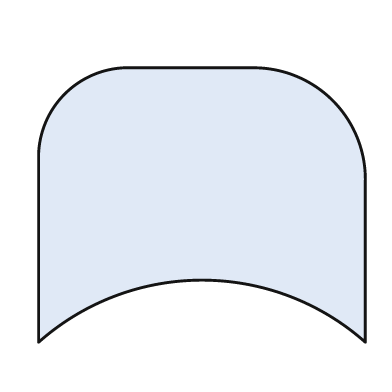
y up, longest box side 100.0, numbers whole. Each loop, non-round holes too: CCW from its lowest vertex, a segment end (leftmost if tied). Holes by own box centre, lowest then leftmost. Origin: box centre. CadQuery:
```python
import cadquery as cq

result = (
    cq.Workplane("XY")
    .moveTo(-50.0, -42.0)
    .threePointArc((0.0, -23.0), (50.0, -42.0))
    .lineTo(50.0, 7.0)
    .threePointArc((40.0, 32.0), (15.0, 42.0))
    .lineTo(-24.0, 42.0)
    .threePointArc((-42.0, 34.0), (-50.0, 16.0))
    .close()
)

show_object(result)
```